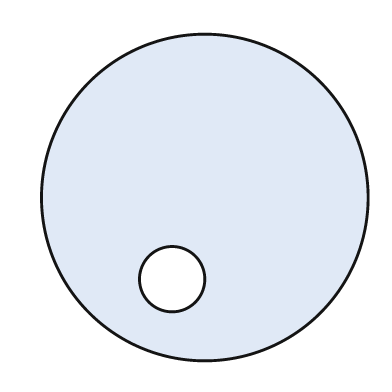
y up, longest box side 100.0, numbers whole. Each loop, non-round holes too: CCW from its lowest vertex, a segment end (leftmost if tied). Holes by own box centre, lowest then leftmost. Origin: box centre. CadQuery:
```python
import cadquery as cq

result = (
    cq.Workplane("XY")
    .moveTo(0.0, 0.0)
    .circle(50.0)
    .moveTo(-10.0, -25.0)
    .circle(10.0)
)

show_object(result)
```